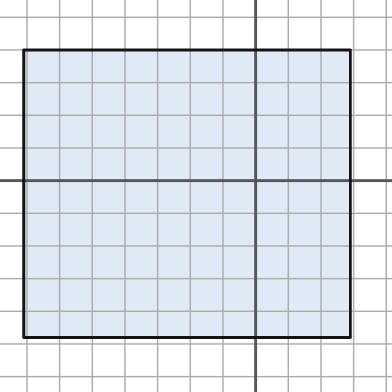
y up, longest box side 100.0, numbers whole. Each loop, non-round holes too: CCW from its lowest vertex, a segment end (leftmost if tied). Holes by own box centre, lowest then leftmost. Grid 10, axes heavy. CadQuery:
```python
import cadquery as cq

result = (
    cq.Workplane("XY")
    .moveTo(-71.0, -48.0)
    .lineTo(29.0, -48.0)
    .lineTo(29.0, 40.0)
    .lineTo(-71.0, 40.0)
    .close()
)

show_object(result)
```